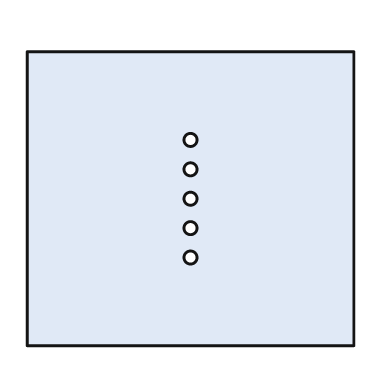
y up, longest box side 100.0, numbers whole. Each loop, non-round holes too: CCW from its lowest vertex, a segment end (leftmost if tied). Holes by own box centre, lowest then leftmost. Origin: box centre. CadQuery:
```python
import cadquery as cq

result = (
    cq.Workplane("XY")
    .moveTo(-50.0, -45.0)
    .lineTo(50.0, -45.0)
    .lineTo(50.0, 45.0)
    .lineTo(-50.0, 45.0)
    .close()
    .moveTo(0.0, -18.0)
    .circle(2.0)
    .moveTo(0.0, -9.0)
    .circle(2.0)
    .moveTo(0.0, 0.0)
    .circle(2.0)
    .moveTo(0.0, 9.0)
    .circle(2.0)
    .moveTo(0.0, 18.0)
    .circle(2.0)
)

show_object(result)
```